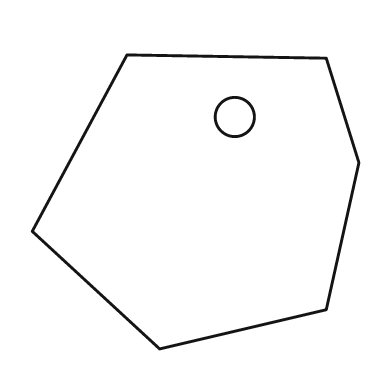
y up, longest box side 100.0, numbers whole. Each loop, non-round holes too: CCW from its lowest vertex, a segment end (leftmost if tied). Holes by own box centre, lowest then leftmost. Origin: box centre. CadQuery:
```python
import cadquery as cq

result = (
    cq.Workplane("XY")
    .moveTo(-11.0, -45.0)
    .lineTo(40.0, -33.0)
    .lineTo(50.0, 12.0)
    .lineTo(40.0, 44.0)
    .lineTo(-21.0, 45.0)
    .lineTo(-50.0, -9.0)
    .close()
    .moveTo(12.0, 26.0)
    .circle(6.0)
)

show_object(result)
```